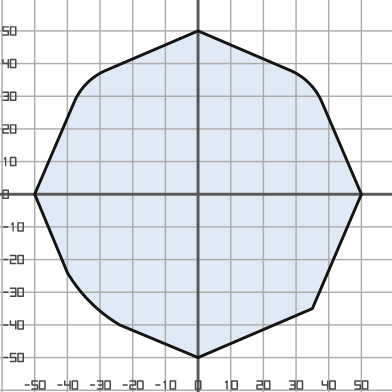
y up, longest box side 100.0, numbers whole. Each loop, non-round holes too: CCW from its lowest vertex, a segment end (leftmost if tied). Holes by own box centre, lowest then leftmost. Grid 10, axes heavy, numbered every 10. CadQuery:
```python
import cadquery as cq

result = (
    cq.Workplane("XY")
    .moveTo(0.0, -50.0)
    .lineTo(35.0, -35.0)
    .lineTo(50.0, 0.0)
    .lineTo(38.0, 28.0)
    .threePointArc((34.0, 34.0), (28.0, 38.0))
    .lineTo(0.0, 50.0)
    .lineTo(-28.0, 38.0)
    .threePointArc((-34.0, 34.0), (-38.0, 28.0))
    .lineTo(-50.0, 0.0)
    .lineTo(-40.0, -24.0)
    .threePointArc((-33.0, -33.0), (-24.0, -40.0))
    .close()
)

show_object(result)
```